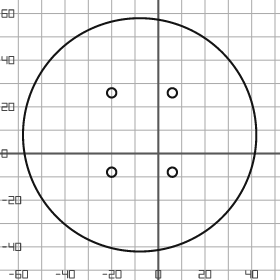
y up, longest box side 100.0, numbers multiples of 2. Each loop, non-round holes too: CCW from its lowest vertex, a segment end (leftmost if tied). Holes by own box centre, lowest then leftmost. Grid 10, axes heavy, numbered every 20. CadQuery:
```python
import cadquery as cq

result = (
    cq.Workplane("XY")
    .moveTo(-8.0, 8.0)
    .circle(50.0)
    .moveTo(-20.0, -8.0)
    .circle(2.0)
    .moveTo(6.0, -8.0)
    .circle(2.0)
    .moveTo(-20.0, 26.0)
    .circle(2.0)
    .moveTo(6.0, 26.0)
    .circle(2.0)
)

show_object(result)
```